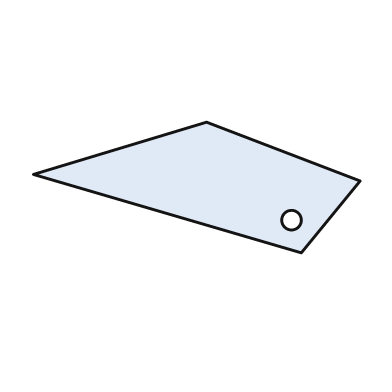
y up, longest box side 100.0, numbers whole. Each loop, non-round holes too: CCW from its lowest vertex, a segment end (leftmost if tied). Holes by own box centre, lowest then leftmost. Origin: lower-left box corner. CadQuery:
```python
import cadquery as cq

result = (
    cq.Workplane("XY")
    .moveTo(82.0, 0.0)
    .lineTo(100.0, 22.0)
    .lineTo(53.0, 40.0)
    .lineTo(0.0, 24.0)
    .close()
    .moveTo(79.0, 10.0)
    .circle(3.0)
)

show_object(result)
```